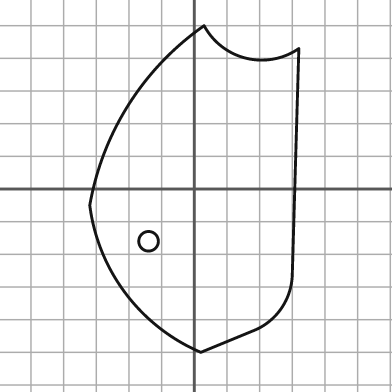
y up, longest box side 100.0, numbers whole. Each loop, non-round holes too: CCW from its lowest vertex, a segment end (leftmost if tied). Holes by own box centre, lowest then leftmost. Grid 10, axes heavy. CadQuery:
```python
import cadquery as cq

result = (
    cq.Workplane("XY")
    .moveTo(2.0, -50.0)
    .lineTo(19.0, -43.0)
    .threePointArc((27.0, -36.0), (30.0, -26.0))
    .lineTo(32.0, 43.0)
    .threePointArc((16.0, 40.0), (3.0, 50.0))
    .threePointArc((-20.0, 26.0), (-32.0, -5.0))
    .threePointArc((-21.0, -32.0), (2.0, -50.0))
    .close()
    .moveTo(-14.0, -16.0)
    .circle(3.0)
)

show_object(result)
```